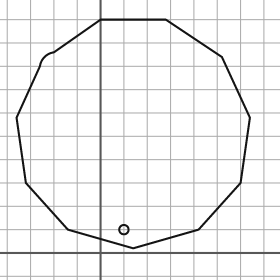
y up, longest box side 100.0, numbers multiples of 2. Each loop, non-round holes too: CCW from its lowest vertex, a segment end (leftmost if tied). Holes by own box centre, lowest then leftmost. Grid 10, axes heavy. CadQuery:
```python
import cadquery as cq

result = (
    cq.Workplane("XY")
    .moveTo(14.0, 2.0)
    .lineTo(42.0, 10.0)
    .lineTo(60.0, 30.0)
    .lineTo(64.0, 58.0)
    .lineTo(52.0, 84.0)
    .lineTo(28.0, 100.0)
    .lineTo(0.0, 100.0)
    .lineTo(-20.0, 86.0)
    .threePointArc((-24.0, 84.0), (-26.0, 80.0))
    .lineTo(-36.0, 58.0)
    .lineTo(-32.0, 30.0)
    .lineTo(-14.0, 10.0)
    .close()
    .moveTo(10.0, 10.0)
    .circle(2.0)
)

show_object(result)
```